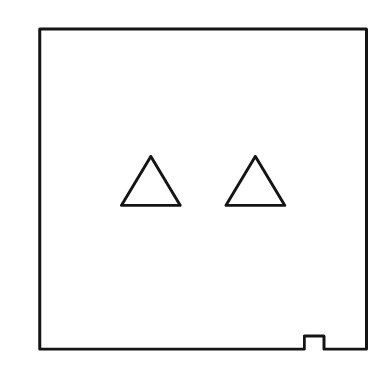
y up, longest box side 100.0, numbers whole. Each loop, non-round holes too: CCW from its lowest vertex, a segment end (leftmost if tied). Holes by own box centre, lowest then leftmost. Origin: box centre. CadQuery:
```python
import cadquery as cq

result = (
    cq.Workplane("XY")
    .moveTo(-50.0, -49.0)
    .lineTo(31.0, -49.0)
    .lineTo(31.0, -45.0)
    .lineTo(37.0, -45.0)
    .lineTo(37.0, -49.0)
    .lineTo(50.0, -49.0)
    .lineTo(50.0, 49.0)
    .lineTo(-50.0, 49.0)
    .close()
    .moveTo(-25.0, -5.0)
    .lineTo(-7.0, -5.0)
    .lineTo(-16.0, 10.0)
    .close()
    .moveTo(7.0, -5.0)
    .lineTo(25.0, -5.0)
    .lineTo(16.0, 10.0)
    .close()
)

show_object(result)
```